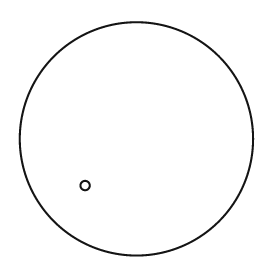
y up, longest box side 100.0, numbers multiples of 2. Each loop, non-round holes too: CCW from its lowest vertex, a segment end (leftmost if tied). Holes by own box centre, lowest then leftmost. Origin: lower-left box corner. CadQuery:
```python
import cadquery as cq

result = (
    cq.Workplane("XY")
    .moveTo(50.0, 50.0)
    .circle(50.0)
    .moveTo(28.0, 30.0)
    .circle(2.0)
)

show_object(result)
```